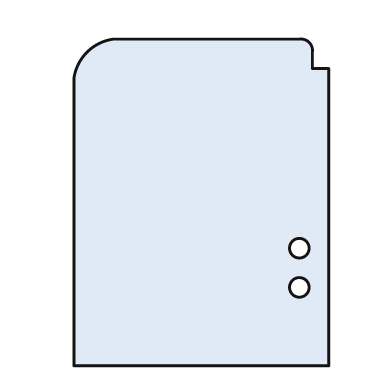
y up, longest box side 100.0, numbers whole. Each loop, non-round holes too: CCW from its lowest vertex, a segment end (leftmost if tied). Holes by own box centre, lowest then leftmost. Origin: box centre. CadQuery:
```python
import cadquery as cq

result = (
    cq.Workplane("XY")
    .moveTo(-39.0, -50.0)
    .lineTo(39.0, -50.0)
    .lineTo(39.0, 41.0)
    .lineTo(34.0, 41.0)
    .lineTo(34.0, 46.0)
    .threePointArc((33.0, 49.0), (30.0, 50.0))
    .lineTo(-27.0, 50.0)
    .threePointArc((-35.0, 46.0), (-39.0, 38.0))
    .close()
    .moveTo(30.0, -26.0)
    .circle(3.0)
    .moveTo(30.0, -14.0)
    .circle(3.0)
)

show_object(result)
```